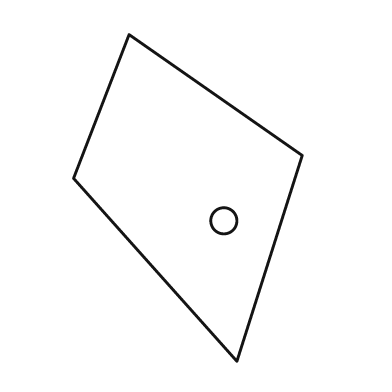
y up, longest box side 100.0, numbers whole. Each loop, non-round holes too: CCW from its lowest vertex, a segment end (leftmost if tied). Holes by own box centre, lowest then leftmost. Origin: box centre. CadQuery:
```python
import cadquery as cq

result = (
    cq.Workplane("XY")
    .moveTo(15.0, -50.0)
    .lineTo(35.0, 13.0)
    .lineTo(-18.0, 50.0)
    .lineTo(-35.0, 6.0)
    .close()
    .moveTo(11.0, -7.0)
    .circle(4.0)
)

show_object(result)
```